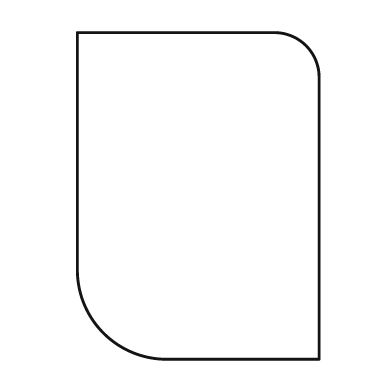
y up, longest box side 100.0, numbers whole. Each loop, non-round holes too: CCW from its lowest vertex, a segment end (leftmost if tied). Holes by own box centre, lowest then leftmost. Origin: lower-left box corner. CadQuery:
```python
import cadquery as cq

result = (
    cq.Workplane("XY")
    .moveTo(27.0, 0.0)
    .lineTo(74.0, 0.0)
    .lineTo(74.0, 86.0)
    .threePointArc((70.0, 96.0), (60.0, 100.0))
    .lineTo(0.0, 100.0)
    .lineTo(0.0, 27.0)
    .threePointArc((8.0, 8.0), (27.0, 0.0))
    .close()
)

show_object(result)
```